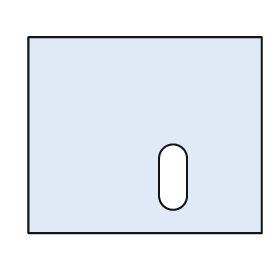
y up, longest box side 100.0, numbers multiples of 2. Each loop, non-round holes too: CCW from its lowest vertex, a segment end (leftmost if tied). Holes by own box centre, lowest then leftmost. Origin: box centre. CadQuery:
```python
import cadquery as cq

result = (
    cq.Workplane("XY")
    .moveTo(-50.0, -42.0)
    .lineTo(50.0, -42.0)
    .lineTo(50.0, 42.0)
    .lineTo(-50.0, 42.0)
    .close()
    .moveTo(6.0, -26.0)
    .threePointArc((12.0, -32.0), (18.0, -26.0))
    .lineTo(18.0, -10.0)
    .threePointArc((12.0, -4.0), (6.0, -10.0))
    .close()
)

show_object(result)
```